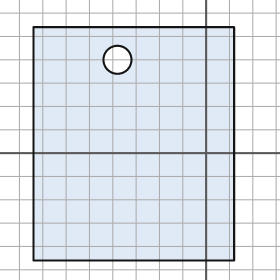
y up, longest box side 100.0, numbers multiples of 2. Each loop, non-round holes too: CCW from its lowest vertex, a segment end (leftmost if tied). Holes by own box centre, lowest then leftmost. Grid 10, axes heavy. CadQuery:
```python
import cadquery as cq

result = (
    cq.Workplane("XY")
    .moveTo(-74.0, -46.0)
    .lineTo(12.0, -46.0)
    .lineTo(12.0, 54.0)
    .lineTo(-74.0, 54.0)
    .close()
    .moveTo(-38.0, 40.0)
    .circle(6.0)
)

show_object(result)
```